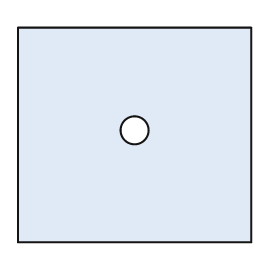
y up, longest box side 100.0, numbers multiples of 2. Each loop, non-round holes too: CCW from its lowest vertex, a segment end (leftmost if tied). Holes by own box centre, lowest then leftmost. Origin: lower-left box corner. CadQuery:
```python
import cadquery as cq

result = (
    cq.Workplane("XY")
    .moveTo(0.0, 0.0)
    .lineTo(100.0, 0.0)
    .lineTo(100.0, 92.0)
    .lineTo(0.0, 92.0)
    .close()
    .moveTo(50.0, 48.0)
    .circle(6.0)
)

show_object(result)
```